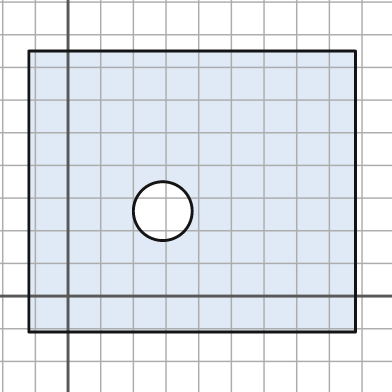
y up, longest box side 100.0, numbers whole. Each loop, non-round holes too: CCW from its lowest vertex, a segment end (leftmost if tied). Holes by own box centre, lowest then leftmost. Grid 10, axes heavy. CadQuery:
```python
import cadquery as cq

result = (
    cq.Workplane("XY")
    .moveTo(-12.0, -11.0)
    .lineTo(88.0, -11.0)
    .lineTo(88.0, 75.0)
    .lineTo(-12.0, 75.0)
    .close()
    .moveTo(29.0, 26.0)
    .circle(9.0)
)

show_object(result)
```